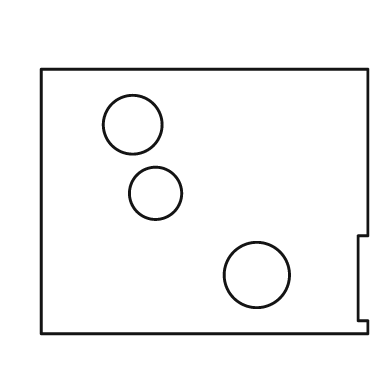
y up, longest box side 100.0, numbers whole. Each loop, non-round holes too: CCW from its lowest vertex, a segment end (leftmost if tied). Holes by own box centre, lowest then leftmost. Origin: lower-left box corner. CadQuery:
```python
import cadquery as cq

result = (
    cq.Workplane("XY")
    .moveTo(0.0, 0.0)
    .lineTo(100.0, 0.0)
    .lineTo(100.0, 4.0)
    .lineTo(97.0, 4.0)
    .lineTo(97.0, 30.0)
    .lineTo(100.0, 30.0)
    .lineTo(100.0, 81.0)
    .lineTo(0.0, 81.0)
    .close()
    .moveTo(66.0, 18.0)
    .circle(10.0)
    .moveTo(35.0, 43.0)
    .circle(8.0)
    .moveTo(28.0, 64.0)
    .circle(9.0)
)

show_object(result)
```